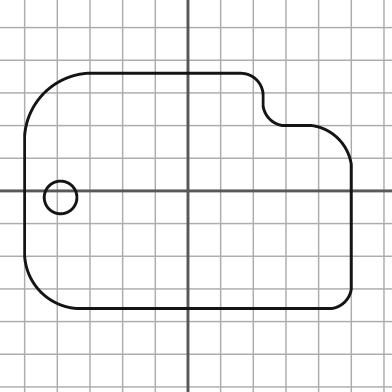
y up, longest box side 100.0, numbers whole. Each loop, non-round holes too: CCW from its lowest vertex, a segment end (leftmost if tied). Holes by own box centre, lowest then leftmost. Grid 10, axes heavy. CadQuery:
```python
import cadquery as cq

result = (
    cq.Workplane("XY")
    .moveTo(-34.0, -36.0)
    .lineTo(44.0, -36.0)
    .threePointArc((48.0, -34.0), (50.0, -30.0))
    .lineTo(50.0, 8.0)
    .threePointArc((46.0, 16.0), (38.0, 20.0))
    .lineTo(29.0, 20.0)
    .threePointArc((25.0, 22.0), (23.0, 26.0))
    .lineTo(23.0, 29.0)
    .threePointArc((21.0, 34.0), (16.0, 36.0))
    .lineTo(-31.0, 36.0)
    .threePointArc((-44.0, 30.0), (-50.0, 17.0))
    .lineTo(-50.0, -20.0)
    .threePointArc((-45.0, -31.0), (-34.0, -36.0))
    .close()
    .moveTo(-39.0, -2.0)
    .circle(5.0)
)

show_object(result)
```